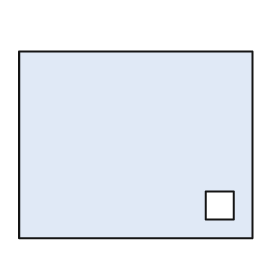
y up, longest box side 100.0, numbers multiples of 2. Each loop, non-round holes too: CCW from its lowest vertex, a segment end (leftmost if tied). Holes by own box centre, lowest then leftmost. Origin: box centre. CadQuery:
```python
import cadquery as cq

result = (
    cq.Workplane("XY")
    .moveTo(-50.0, -40.0)
    .lineTo(50.0, -40.0)
    .lineTo(50.0, 40.0)
    .lineTo(-50.0, 40.0)
    .close()
    .moveTo(30.0, -32.0)
    .lineTo(42.0, -32.0)
    .lineTo(42.0, -20.0)
    .lineTo(30.0, -20.0)
    .close()
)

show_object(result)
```